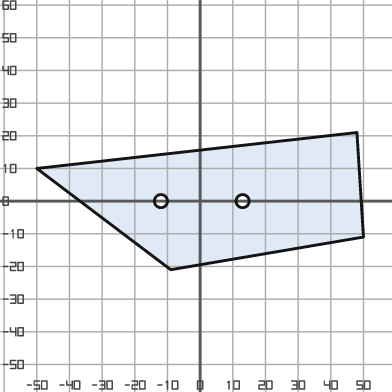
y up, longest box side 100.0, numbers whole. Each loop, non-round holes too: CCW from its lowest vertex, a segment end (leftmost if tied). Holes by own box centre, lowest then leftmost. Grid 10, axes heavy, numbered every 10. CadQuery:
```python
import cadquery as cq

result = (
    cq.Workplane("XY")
    .moveTo(-9.0, -21.0)
    .lineTo(50.0, -11.0)
    .lineTo(48.0, 21.0)
    .lineTo(-50.0, 10.0)
    .close()
    .moveTo(-12.0, 0.0)
    .circle(2.0)
    .moveTo(13.0, 0.0)
    .circle(2.0)
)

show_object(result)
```